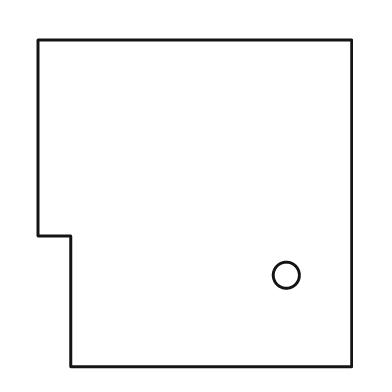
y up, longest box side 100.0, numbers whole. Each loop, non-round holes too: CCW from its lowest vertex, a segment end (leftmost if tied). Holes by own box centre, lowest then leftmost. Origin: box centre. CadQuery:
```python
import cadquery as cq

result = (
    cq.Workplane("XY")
    .moveTo(-38.0, -50.0)
    .lineTo(48.0, -50.0)
    .lineTo(48.0, 50.0)
    .lineTo(-48.0, 50.0)
    .lineTo(-48.0, -10.0)
    .lineTo(-38.0, -10.0)
    .close()
    .moveTo(28.0, -22.0)
    .circle(4.0)
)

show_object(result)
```